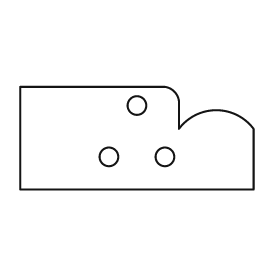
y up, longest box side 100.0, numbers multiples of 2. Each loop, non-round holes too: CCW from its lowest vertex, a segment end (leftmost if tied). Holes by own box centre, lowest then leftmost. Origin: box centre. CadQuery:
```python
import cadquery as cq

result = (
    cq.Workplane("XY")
    .moveTo(-50.0, -22.0)
    .lineTo(50.0, -22.0)
    .lineTo(50.0, 4.0)
    .threePointArc((34.0, 12.0), (18.0, 4.0))
    .lineTo(18.0, 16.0)
    .threePointArc((16.0, 20.0), (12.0, 22.0))
    .lineTo(-50.0, 22.0)
    .close()
    .moveTo(-12.0, -8.0)
    .circle(4.0)
    .moveTo(12.0, -8.0)
    .circle(4.0)
    .moveTo(0.0, 14.0)
    .circle(4.0)
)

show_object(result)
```